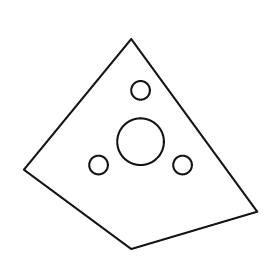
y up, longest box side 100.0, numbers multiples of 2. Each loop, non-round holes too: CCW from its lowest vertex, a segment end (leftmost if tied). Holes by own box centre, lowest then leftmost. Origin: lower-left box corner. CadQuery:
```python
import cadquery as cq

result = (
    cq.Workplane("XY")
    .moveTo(46.0, 0.0)
    .lineTo(100.0, 16.0)
    .lineTo(46.0, 90.0)
    .lineTo(0.0, 34.0)
    .close()
    .moveTo(32.0, 36.0)
    .circle(4.0)
    .moveTo(68.0, 36.0)
    .circle(4.0)
    .moveTo(50.0, 46.0)
    .circle(10.0)
    .moveTo(50.0, 68.0)
    .circle(4.0)
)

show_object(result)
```